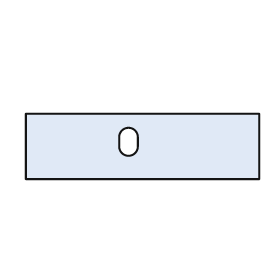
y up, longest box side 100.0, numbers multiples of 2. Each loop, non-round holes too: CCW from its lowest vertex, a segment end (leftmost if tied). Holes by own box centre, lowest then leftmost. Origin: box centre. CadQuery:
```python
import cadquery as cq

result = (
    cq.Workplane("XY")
    .moveTo(-50.0, -14.0)
    .lineTo(50.0, -14.0)
    .lineTo(50.0, 14.0)
    .lineTo(-50.0, 14.0)
    .close()
    .moveTo(-10.0, 0.0)
    .threePointArc((-6.0, -4.0), (-2.0, 0.0))
    .lineTo(-2.0, 4.0)
    .threePointArc((-6.0, 8.0), (-10.0, 4.0))
    .close()
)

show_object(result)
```